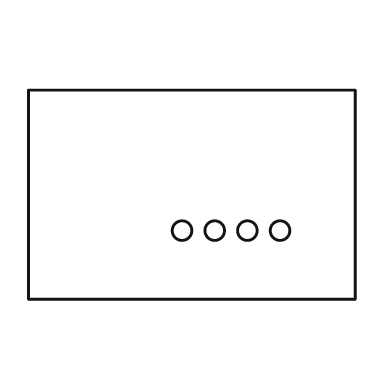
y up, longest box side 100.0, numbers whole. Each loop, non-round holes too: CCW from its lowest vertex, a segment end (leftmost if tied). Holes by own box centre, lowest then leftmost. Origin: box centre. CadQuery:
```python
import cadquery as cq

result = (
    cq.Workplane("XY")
    .moveTo(-50.0, -32.0)
    .lineTo(50.0, -32.0)
    .lineTo(50.0, 32.0)
    .lineTo(-50.0, 32.0)
    .close()
    .moveTo(-3.0, -11.0)
    .circle(3.0)
    .moveTo(7.0, -11.0)
    .circle(3.0)
    .moveTo(17.0, -11.0)
    .circle(3.0)
    .moveTo(27.0, -11.0)
    .circle(3.0)
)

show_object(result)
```